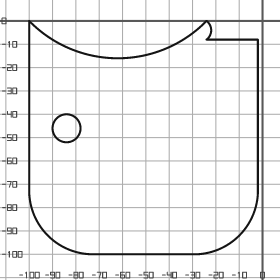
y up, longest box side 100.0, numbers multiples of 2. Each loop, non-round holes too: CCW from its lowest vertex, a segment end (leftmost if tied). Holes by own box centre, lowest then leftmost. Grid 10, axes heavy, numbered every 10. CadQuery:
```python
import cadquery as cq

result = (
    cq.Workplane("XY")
    .moveTo(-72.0, -100.0)
    .lineTo(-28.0, -100.0)
    .threePointArc((-10.0, -92.0), (-2.0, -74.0))
    .lineTo(-2.0, -8.0)
    .lineTo(-24.0, -8.0)
    .threePointArc((-22.0, -4.0), (-24.0, 0.0))
    .threePointArc((-62.0, -16.0), (-100.0, 0.0))
    .lineTo(-100.0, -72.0)
    .threePointArc((-92.0, -92.0), (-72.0, -100.0))
    .close()
    .moveTo(-84.0, -46.0)
    .circle(6.0)
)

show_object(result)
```